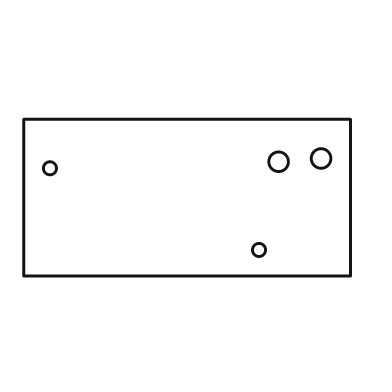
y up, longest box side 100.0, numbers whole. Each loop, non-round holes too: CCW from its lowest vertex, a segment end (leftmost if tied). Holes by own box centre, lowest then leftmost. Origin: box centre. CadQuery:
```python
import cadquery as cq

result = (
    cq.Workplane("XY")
    .moveTo(-50.0, -24.0)
    .lineTo(50.0, -24.0)
    .lineTo(50.0, 24.0)
    .lineTo(-50.0, 24.0)
    .close()
    .moveTo(22.0, -16.0)
    .circle(2.0)
    .moveTo(-42.0, 9.0)
    .circle(2.0)
    .moveTo(28.0, 11.0)
    .circle(3.0)
    .moveTo(41.0, 12.0)
    .circle(3.0)
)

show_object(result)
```